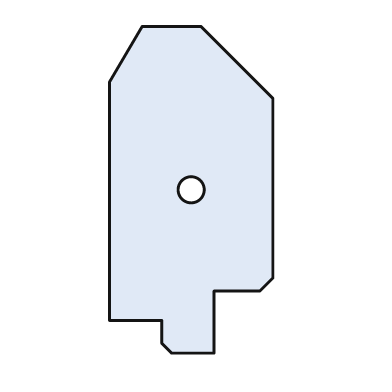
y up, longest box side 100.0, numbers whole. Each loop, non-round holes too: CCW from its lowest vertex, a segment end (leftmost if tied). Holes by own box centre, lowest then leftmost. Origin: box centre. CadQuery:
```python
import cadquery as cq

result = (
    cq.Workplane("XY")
    .moveTo(-6.0, -50.0)
    .lineTo(7.0, -50.0)
    .lineTo(7.0, -31.0)
    .lineTo(21.0, -31.0)
    .lineTo(25.0, -27.0)
    .lineTo(25.0, 28.0)
    .lineTo(3.0, 50.0)
    .lineTo(-15.0, 50.0)
    .lineTo(-25.0, 33.0)
    .lineTo(-25.0, -40.0)
    .lineTo(-9.0, -40.0)
    .lineTo(-9.0, -47.0)
    .close()
    .moveTo(0.0, 0.0)
    .circle(4.0)
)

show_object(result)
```